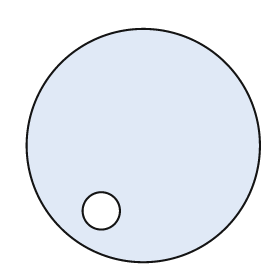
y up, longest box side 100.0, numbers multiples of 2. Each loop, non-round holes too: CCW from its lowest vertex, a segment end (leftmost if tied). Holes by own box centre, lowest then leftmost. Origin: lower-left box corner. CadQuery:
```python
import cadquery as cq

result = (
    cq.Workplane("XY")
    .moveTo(50.0, 50.0)
    .circle(50.0)
    .moveTo(32.0, 22.0)
    .circle(8.0)
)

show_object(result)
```